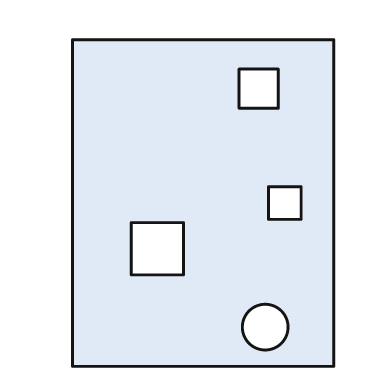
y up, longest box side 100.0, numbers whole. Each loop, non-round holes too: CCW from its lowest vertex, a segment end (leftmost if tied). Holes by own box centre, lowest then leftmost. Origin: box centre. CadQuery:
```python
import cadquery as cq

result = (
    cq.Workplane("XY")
    .moveTo(-40.0, -50.0)
    .lineTo(40.0, -50.0)
    .lineTo(40.0, 50.0)
    .lineTo(-40.0, 50.0)
    .close()
    .moveTo(19.0, -38.0)
    .circle(7.0)
    .moveTo(-22.0, -22.0)
    .lineTo(-6.0, -22.0)
    .lineTo(-6.0, -6.0)
    .lineTo(-22.0, -6.0)
    .close()
    .moveTo(20.0, -5.0)
    .lineTo(30.0, -5.0)
    .lineTo(30.0, 5.0)
    .lineTo(20.0, 5.0)
    .close()
    .moveTo(11.0, 29.0)
    .lineTo(23.0, 29.0)
    .lineTo(23.0, 41.0)
    .lineTo(11.0, 41.0)
    .close()
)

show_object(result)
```